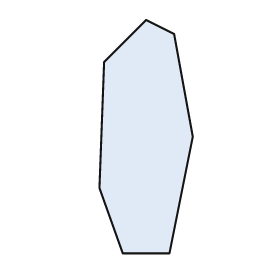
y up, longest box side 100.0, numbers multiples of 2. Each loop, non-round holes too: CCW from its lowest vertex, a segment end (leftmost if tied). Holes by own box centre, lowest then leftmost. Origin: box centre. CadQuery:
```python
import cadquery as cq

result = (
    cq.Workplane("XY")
    .moveTo(-10.0, -50.0)
    .lineTo(10.0, -50.0)
    .lineTo(20.0, 0.0)
    .lineTo(12.0, 44.0)
    .lineTo(0.0, 50.0)
    .lineTo(-18.0, 32.0)
    .lineTo(-20.0, -22.0)
    .close()
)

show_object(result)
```